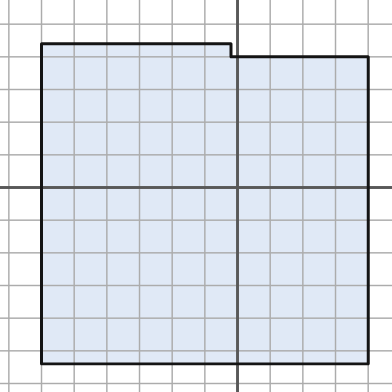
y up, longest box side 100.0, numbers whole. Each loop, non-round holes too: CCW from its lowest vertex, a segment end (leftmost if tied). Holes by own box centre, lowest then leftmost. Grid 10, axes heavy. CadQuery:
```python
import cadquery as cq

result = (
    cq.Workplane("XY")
    .moveTo(-60.0, -54.0)
    .lineTo(40.0, -54.0)
    .lineTo(40.0, 40.0)
    .lineTo(-2.0, 40.0)
    .lineTo(-2.0, 44.0)
    .lineTo(-60.0, 44.0)
    .close()
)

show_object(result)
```